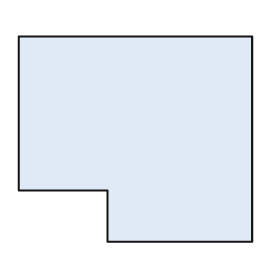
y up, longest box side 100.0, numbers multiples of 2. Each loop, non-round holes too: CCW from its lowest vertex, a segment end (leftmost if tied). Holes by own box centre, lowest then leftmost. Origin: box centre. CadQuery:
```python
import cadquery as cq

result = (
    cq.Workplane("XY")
    .moveTo(-12.0, -44.0)
    .lineTo(50.0, -44.0)
    .lineTo(50.0, 44.0)
    .lineTo(-50.0, 44.0)
    .lineTo(-50.0, -22.0)
    .lineTo(-12.0, -22.0)
    .close()
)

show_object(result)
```